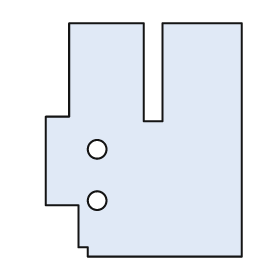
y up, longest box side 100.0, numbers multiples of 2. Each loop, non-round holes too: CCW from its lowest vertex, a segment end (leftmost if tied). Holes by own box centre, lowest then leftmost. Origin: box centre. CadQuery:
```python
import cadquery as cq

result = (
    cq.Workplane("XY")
    .moveTo(-24.0, -50.0)
    .lineTo(42.0, -50.0)
    .lineTo(42.0, 50.0)
    .lineTo(8.0, 50.0)
    .lineTo(8.0, 8.0)
    .lineTo(0.0, 8.0)
    .lineTo(0.0, 50.0)
    .lineTo(-32.0, 50.0)
    .lineTo(-32.0, 10.0)
    .lineTo(-42.0, 10.0)
    .lineTo(-42.0, -28.0)
    .lineTo(-28.0, -28.0)
    .lineTo(-28.0, -46.0)
    .lineTo(-24.0, -46.0)
    .close()
    .moveTo(-20.0, -26.0)
    .circle(4.0)
    .moveTo(-20.0, -4.0)
    .circle(4.0)
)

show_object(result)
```